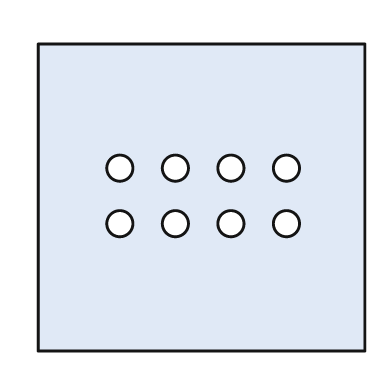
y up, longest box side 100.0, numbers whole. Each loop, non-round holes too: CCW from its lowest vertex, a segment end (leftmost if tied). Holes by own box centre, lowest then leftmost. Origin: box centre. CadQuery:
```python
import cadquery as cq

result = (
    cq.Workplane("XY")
    .moveTo(-50.0, -47.0)
    .lineTo(50.0, -47.0)
    .lineTo(50.0, 47.0)
    .lineTo(-50.0, 47.0)
    .close()
    .moveTo(-25.0, -8.0)
    .circle(4.0)
    .moveTo(-8.0, -8.0)
    .circle(4.0)
    .moveTo(9.0, -8.0)
    .circle(4.0)
    .moveTo(26.0, -8.0)
    .circle(4.0)
    .moveTo(-25.0, 9.0)
    .circle(4.0)
    .moveTo(-8.0, 9.0)
    .circle(4.0)
    .moveTo(9.0, 9.0)
    .circle(4.0)
    .moveTo(26.0, 9.0)
    .circle(4.0)
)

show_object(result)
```